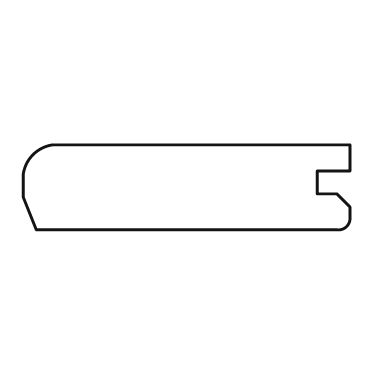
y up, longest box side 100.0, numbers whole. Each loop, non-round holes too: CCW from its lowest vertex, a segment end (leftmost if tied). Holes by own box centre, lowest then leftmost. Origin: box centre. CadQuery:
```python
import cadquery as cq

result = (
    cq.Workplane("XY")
    .moveTo(-46.0, -13.0)
    .lineTo(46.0, -13.0)
    .threePointArc((49.0, -12.0), (50.0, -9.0))
    .lineTo(50.0, -6.0)
    .lineTo(46.0, -2.0)
    .lineTo(40.0, -2.0)
    .lineTo(40.0, 5.0)
    .lineTo(50.0, 5.0)
    .lineTo(50.0, 13.0)
    .lineTo(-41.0, 13.0)
    .threePointArc((-47.0, 10.0), (-50.0, 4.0))
    .lineTo(-50.0, -3.0)
    .close()
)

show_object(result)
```